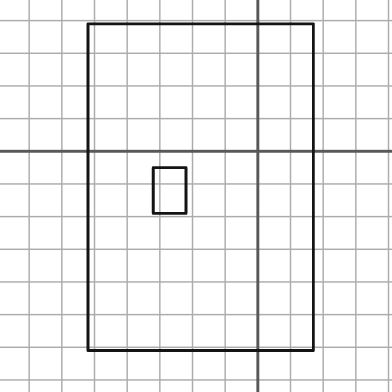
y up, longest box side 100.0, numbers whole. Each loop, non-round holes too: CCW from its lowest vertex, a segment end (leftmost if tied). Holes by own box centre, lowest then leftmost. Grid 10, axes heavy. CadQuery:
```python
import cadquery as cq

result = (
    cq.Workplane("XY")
    .moveTo(-52.0, -61.0)
    .lineTo(17.0, -61.0)
    .lineTo(17.0, 39.0)
    .lineTo(-52.0, 39.0)
    .close()
    .moveTo(-32.0, -19.0)
    .lineTo(-22.0, -19.0)
    .lineTo(-22.0, -5.0)
    .lineTo(-32.0, -5.0)
    .close()
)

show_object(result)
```